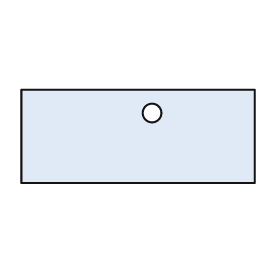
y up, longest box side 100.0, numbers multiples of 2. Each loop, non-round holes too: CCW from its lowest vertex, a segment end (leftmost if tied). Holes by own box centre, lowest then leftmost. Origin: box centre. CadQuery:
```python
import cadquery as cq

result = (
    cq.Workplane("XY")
    .moveTo(-50.0, -20.0)
    .lineTo(50.0, -20.0)
    .lineTo(50.0, 20.0)
    .lineTo(-50.0, 20.0)
    .close()
    .moveTo(6.0, 10.0)
    .circle(4.0)
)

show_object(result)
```